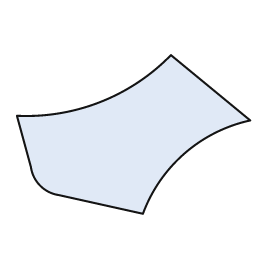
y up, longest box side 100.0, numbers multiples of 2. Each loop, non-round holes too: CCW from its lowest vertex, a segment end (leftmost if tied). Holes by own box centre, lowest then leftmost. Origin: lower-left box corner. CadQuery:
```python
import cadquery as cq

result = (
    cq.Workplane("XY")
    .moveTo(54.0, 0.0)
    .threePointArc((72.0, 26.0), (100.0, 40.0))
    .lineTo(66.0, 68.0)
    .threePointArc((36.0, 48.0), (0.0, 42.0))
    .lineTo(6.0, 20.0)
    .threePointArc((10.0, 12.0), (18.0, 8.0))
    .close()
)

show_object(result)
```